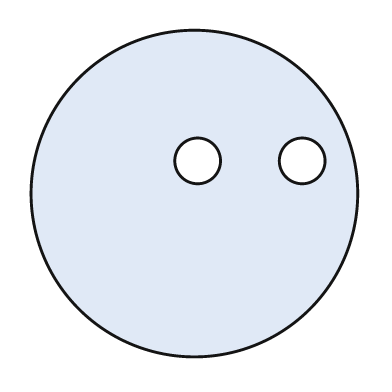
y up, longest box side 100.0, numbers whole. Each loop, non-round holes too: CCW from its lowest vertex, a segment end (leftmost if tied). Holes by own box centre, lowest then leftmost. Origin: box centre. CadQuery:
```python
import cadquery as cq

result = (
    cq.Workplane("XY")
    .moveTo(0.0, 0.0)
    .circle(50.0)
    .moveTo(1.0, 10.0)
    .circle(7.0)
    .moveTo(33.0, 10.0)
    .circle(7.0)
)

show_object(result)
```